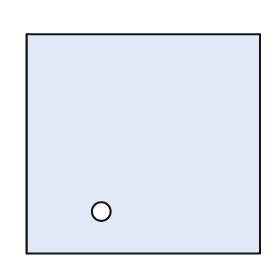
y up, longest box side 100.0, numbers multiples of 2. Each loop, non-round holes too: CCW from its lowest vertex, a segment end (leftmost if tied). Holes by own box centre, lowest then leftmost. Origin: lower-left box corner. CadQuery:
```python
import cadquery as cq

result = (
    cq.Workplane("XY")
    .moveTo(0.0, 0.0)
    .lineTo(100.0, 0.0)
    .lineTo(100.0, 94.0)
    .lineTo(0.0, 94.0)
    .close()
    .moveTo(32.0, 18.0)
    .circle(4.0)
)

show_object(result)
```